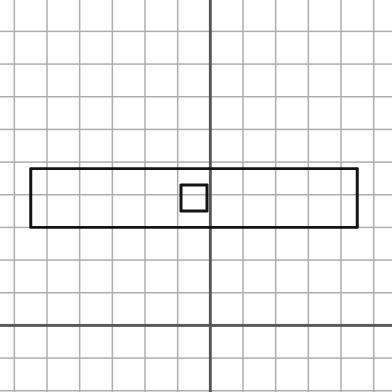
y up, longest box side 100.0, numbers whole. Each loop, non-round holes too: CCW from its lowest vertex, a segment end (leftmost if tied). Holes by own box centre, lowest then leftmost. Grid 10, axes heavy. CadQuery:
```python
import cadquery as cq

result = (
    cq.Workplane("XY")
    .moveTo(-55.0, 30.0)
    .lineTo(45.0, 30.0)
    .lineTo(45.0, 48.0)
    .lineTo(-55.0, 48.0)
    .close()
    .moveTo(-9.0, 35.0)
    .lineTo(-1.0, 35.0)
    .lineTo(-1.0, 43.0)
    .lineTo(-9.0, 43.0)
    .close()
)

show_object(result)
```